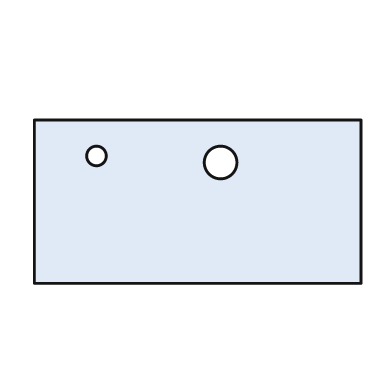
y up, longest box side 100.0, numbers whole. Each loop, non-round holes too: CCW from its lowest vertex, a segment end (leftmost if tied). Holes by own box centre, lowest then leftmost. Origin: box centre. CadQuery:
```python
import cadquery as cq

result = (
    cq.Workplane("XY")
    .moveTo(-50.0, -25.0)
    .lineTo(50.0, -25.0)
    .lineTo(50.0, 25.0)
    .lineTo(-50.0, 25.0)
    .close()
    .moveTo(7.0, 12.0)
    .circle(5.0)
    .moveTo(-31.0, 14.0)
    .circle(3.0)
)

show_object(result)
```